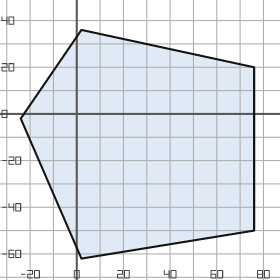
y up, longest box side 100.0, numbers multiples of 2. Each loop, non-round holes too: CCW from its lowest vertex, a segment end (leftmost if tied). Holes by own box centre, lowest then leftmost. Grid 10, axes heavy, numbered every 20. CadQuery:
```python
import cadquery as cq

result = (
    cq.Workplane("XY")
    .moveTo(2.0, -62.0)
    .lineTo(76.0, -50.0)
    .lineTo(76.0, 20.0)
    .lineTo(2.0, 36.0)
    .lineTo(-24.0, -2.0)
    .close()
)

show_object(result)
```